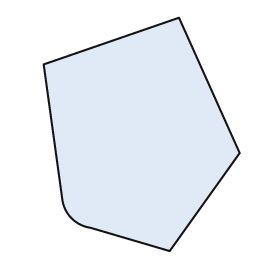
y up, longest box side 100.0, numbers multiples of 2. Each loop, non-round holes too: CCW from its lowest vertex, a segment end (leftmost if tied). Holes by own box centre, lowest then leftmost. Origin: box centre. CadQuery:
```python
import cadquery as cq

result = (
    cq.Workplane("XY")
    .moveTo(12.0, -50.0)
    .lineTo(42.0, -8.0)
    .lineTo(16.0, 50.0)
    .lineTo(-42.0, 30.0)
    .lineTo(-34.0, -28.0)
    .threePointArc((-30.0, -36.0), (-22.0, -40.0))
    .close()
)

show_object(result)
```